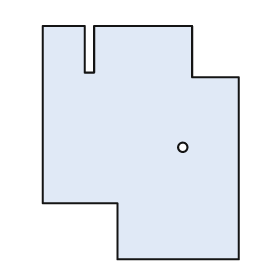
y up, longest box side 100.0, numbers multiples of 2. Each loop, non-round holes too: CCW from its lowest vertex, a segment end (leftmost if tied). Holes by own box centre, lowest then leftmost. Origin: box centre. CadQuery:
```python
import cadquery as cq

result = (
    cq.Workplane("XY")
    .moveTo(-10.0, -50.0)
    .lineTo(42.0, -50.0)
    .lineTo(42.0, 28.0)
    .lineTo(22.0, 28.0)
    .lineTo(22.0, 50.0)
    .lineTo(-20.0, 50.0)
    .lineTo(-20.0, 30.0)
    .lineTo(-24.0, 30.0)
    .lineTo(-24.0, 50.0)
    .lineTo(-42.0, 50.0)
    .lineTo(-42.0, -26.0)
    .lineTo(-10.0, -26.0)
    .close()
    .moveTo(18.0, -2.0)
    .circle(2.0)
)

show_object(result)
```